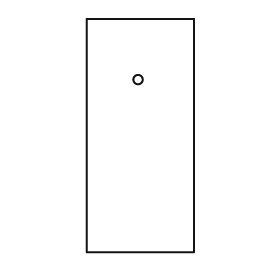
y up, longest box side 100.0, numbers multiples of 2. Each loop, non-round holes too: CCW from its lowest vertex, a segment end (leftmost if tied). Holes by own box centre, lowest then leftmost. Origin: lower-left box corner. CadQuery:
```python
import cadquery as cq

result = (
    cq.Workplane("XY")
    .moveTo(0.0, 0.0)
    .lineTo(46.0, 0.0)
    .lineTo(46.0, 100.0)
    .lineTo(0.0, 100.0)
    .close()
    .moveTo(22.0, 74.0)
    .circle(2.0)
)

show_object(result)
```